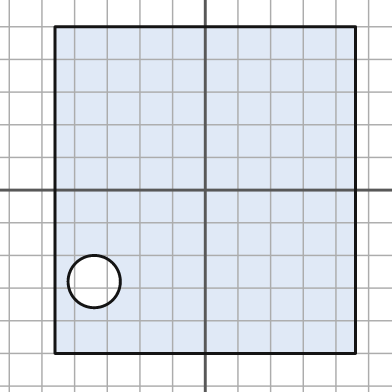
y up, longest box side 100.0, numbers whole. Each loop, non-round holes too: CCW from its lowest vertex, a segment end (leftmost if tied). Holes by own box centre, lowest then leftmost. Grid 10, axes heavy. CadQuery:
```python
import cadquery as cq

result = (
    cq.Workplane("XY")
    .moveTo(-46.0, -50.0)
    .lineTo(46.0, -50.0)
    .lineTo(46.0, 50.0)
    .lineTo(-46.0, 50.0)
    .close()
    .moveTo(-34.0, -28.0)
    .circle(8.0)
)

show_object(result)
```